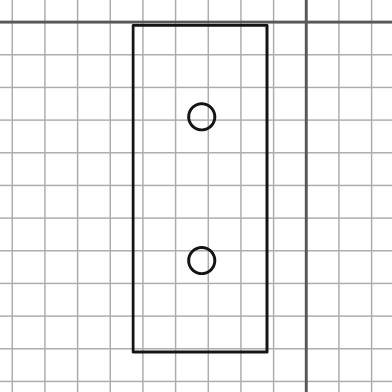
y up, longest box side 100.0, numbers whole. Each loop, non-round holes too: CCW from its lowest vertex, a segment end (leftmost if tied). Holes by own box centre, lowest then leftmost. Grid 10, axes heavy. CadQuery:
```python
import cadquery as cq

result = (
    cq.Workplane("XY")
    .moveTo(-53.0, -101.0)
    .lineTo(-12.0, -101.0)
    .lineTo(-12.0, -1.0)
    .lineTo(-53.0, -1.0)
    .close()
    .moveTo(-32.0, -73.0)
    .circle(4.0)
    .moveTo(-32.0, -29.0)
    .circle(4.0)
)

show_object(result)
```